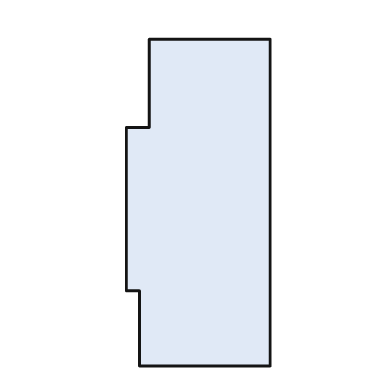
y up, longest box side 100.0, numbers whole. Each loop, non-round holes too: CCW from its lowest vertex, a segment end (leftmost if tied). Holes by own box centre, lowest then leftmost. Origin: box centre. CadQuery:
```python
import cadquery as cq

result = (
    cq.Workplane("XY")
    .moveTo(-18.0, -50.0)
    .lineTo(22.0, -50.0)
    .lineTo(22.0, 50.0)
    .lineTo(-15.0, 50.0)
    .lineTo(-15.0, 23.0)
    .lineTo(-22.0, 23.0)
    .lineTo(-22.0, -27.0)
    .lineTo(-18.0, -27.0)
    .close()
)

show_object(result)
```